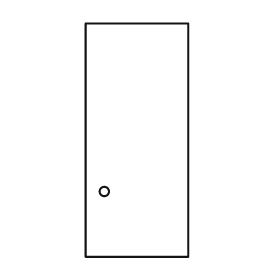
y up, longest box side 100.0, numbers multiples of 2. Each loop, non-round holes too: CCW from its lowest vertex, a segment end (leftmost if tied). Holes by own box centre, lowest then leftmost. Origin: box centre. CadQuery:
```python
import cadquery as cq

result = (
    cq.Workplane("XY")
    .moveTo(-22.0, -50.0)
    .lineTo(22.0, -50.0)
    .lineTo(22.0, 50.0)
    .lineTo(-22.0, 50.0)
    .close()
    .moveTo(-14.0, -22.0)
    .circle(2.0)
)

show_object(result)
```